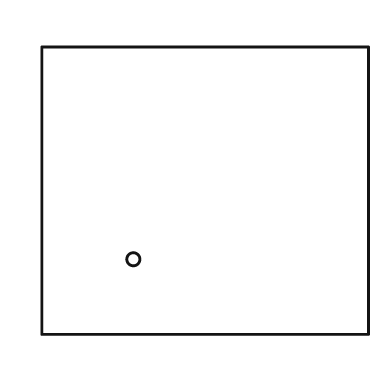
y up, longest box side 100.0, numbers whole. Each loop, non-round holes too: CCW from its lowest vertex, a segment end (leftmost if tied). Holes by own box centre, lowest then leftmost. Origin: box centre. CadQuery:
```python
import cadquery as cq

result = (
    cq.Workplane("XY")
    .moveTo(-50.0, -44.0)
    .lineTo(50.0, -44.0)
    .lineTo(50.0, 44.0)
    .lineTo(-50.0, 44.0)
    .close()
    .moveTo(-22.0, -21.0)
    .circle(2.0)
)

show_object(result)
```